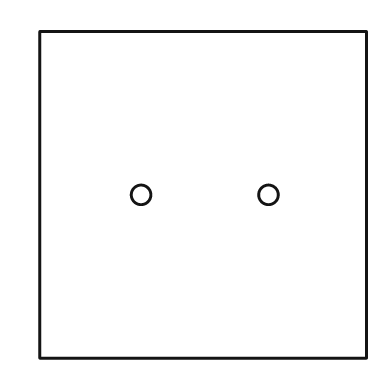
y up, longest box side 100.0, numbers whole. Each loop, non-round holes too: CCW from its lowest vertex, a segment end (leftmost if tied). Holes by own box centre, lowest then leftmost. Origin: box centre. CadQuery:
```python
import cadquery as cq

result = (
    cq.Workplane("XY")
    .moveTo(-50.0, -50.0)
    .lineTo(50.0, -50.0)
    .lineTo(50.0, 50.0)
    .lineTo(-50.0, 50.0)
    .close()
    .moveTo(-19.0, 0.0)
    .circle(3.0)
    .moveTo(20.0, 0.0)
    .circle(3.0)
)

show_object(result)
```